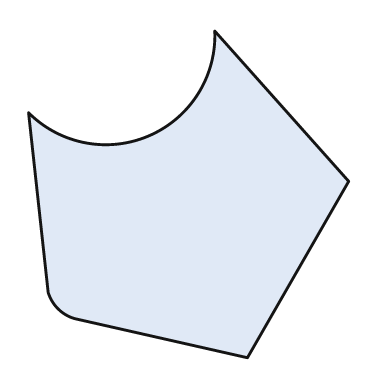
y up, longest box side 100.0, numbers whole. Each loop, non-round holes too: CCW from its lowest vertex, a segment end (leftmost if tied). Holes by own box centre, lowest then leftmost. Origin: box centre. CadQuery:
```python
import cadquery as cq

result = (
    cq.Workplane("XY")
    .moveTo(18.0, -50.0)
    .lineTo(49.0, 4.0)
    .lineTo(8.0, 50.0)
    .threePointArc((-12.0, 18.0), (-49.0, 25.0))
    .lineTo(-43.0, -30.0)
    .threePointArc((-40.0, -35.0), (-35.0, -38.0))
    .close()
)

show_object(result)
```